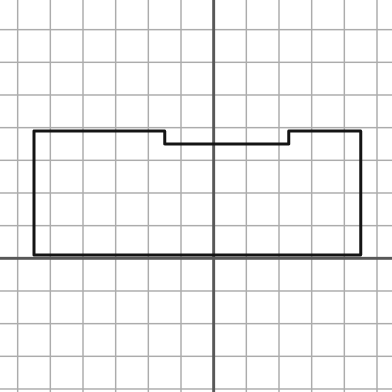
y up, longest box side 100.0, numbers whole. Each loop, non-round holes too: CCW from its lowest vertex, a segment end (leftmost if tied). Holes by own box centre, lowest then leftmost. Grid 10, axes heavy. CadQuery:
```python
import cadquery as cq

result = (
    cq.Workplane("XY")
    .moveTo(-55.0, 1.0)
    .lineTo(45.0, 1.0)
    .lineTo(45.0, 39.0)
    .lineTo(23.0, 39.0)
    .lineTo(23.0, 35.0)
    .lineTo(-15.0, 35.0)
    .lineTo(-15.0, 39.0)
    .lineTo(-55.0, 39.0)
    .close()
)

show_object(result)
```